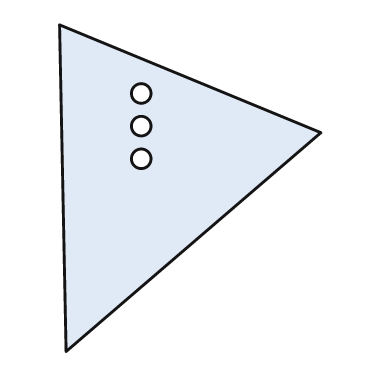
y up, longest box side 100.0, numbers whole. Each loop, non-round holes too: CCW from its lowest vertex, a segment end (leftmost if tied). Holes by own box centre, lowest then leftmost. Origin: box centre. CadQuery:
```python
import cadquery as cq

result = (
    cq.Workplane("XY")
    .moveTo(-38.0, -50.0)
    .lineTo(40.0, 17.0)
    .lineTo(-40.0, 50.0)
    .close()
    .moveTo(-15.0, 9.0)
    .circle(3.0)
    .moveTo(-15.0, 19.0)
    .circle(3.0)
    .moveTo(-15.0, 29.0)
    .circle(3.0)
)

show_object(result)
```